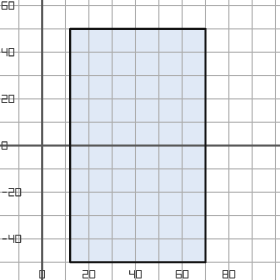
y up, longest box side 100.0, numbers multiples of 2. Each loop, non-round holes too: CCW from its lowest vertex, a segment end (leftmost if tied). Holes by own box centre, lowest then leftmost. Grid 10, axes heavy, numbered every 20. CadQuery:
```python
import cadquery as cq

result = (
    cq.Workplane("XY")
    .moveTo(12.0, -50.0)
    .lineTo(70.0, -50.0)
    .lineTo(70.0, 50.0)
    .lineTo(12.0, 50.0)
    .close()
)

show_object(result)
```